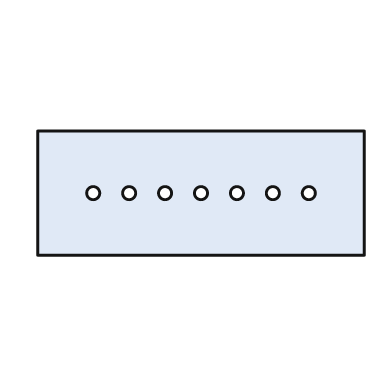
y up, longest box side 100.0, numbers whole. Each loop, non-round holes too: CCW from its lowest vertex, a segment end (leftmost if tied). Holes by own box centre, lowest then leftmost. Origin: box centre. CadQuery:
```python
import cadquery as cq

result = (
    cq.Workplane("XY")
    .moveTo(-50.0, -19.0)
    .lineTo(50.0, -19.0)
    .lineTo(50.0, 19.0)
    .lineTo(-50.0, 19.0)
    .close()
    .moveTo(-33.0, 0.0)
    .circle(2.0)
    .moveTo(-22.0, 0.0)
    .circle(2.0)
    .moveTo(-11.0, 0.0)
    .circle(2.0)
    .moveTo(0.0, 0.0)
    .circle(2.0)
    .moveTo(11.0, 0.0)
    .circle(2.0)
    .moveTo(22.0, 0.0)
    .circle(2.0)
    .moveTo(33.0, 0.0)
    .circle(2.0)
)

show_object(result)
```